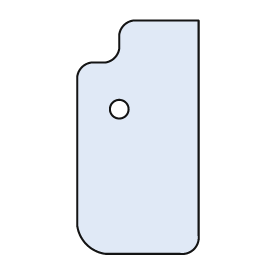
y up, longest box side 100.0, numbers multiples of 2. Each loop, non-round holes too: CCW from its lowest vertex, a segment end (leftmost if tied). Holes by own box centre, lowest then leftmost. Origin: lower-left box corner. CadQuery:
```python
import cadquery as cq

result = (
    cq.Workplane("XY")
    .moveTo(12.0, 0.0)
    .lineTo(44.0, 0.0)
    .threePointArc((50.0, 2.0), (52.0, 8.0))
    .lineTo(52.0, 100.0)
    .lineTo(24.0, 100.0)
    .threePointArc((20.0, 98.0), (18.0, 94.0))
    .lineTo(18.0, 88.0)
    .threePointArc((16.0, 84.0), (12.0, 82.0))
    .lineTo(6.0, 82.0)
    .threePointArc((2.0, 80.0), (0.0, 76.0))
    .lineTo(0.0, 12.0)
    .threePointArc((4.0, 4.0), (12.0, 0.0))
    .close()
    .moveTo(18.0, 62.0)
    .circle(4.0)
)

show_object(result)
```